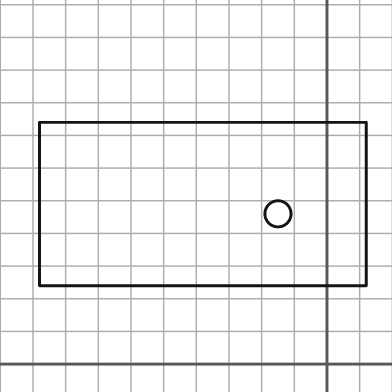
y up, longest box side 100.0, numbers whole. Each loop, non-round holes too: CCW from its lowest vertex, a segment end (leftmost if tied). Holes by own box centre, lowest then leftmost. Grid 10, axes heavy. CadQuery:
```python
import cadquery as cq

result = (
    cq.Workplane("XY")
    .moveTo(-88.0, 24.0)
    .lineTo(12.0, 24.0)
    .lineTo(12.0, 74.0)
    .lineTo(-88.0, 74.0)
    .close()
    .moveTo(-15.0, 46.0)
    .circle(4.0)
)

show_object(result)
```